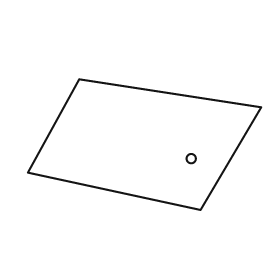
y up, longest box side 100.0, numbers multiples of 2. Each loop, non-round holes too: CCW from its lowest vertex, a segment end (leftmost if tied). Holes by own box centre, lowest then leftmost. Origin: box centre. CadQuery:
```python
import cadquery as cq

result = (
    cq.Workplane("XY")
    .moveTo(24.0, -28.0)
    .lineTo(50.0, 16.0)
    .lineTo(-28.0, 28.0)
    .lineTo(-50.0, -12.0)
    .close()
    .moveTo(20.0, -6.0)
    .circle(2.0)
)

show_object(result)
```